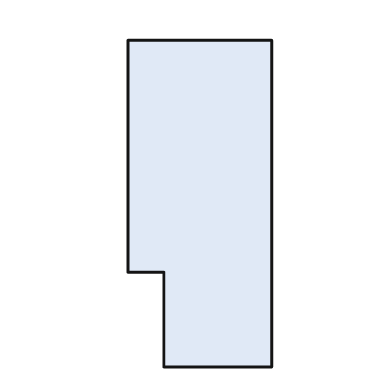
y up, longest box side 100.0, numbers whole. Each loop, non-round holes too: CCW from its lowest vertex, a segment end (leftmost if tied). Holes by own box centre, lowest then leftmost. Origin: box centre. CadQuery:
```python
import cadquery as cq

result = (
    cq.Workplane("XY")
    .moveTo(-11.0, -50.0)
    .lineTo(22.0, -50.0)
    .lineTo(22.0, 50.0)
    .lineTo(-22.0, 50.0)
    .lineTo(-22.0, -21.0)
    .lineTo(-11.0, -21.0)
    .close()
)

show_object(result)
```